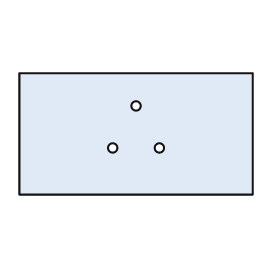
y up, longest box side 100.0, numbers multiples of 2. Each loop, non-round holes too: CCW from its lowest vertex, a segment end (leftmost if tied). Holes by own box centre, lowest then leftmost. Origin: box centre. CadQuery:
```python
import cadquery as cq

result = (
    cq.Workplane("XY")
    .moveTo(-50.0, -26.0)
    .lineTo(50.0, -26.0)
    .lineTo(50.0, 26.0)
    .lineTo(-50.0, 26.0)
    .close()
    .moveTo(-10.0, -6.0)
    .circle(2.0)
    .moveTo(10.0, -6.0)
    .circle(2.0)
    .moveTo(0.0, 12.0)
    .circle(2.0)
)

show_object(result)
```